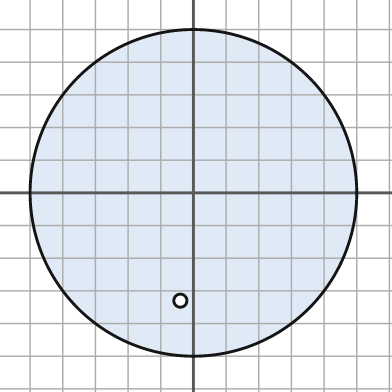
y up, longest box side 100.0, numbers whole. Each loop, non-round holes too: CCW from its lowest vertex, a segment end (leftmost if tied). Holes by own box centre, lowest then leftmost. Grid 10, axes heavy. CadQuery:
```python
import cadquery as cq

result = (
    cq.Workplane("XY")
    .moveTo(0.0, 0.0)
    .circle(50.0)
    .moveTo(-4.0, -33.0)
    .circle(2.0)
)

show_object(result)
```